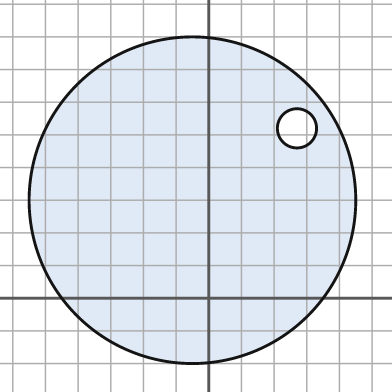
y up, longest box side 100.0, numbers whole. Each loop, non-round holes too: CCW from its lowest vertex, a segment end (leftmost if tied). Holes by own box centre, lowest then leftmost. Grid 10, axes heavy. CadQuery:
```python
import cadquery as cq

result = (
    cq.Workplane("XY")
    .moveTo(-5.0, 30.0)
    .circle(50.0)
    .moveTo(27.0, 52.0)
    .circle(6.0)
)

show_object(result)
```